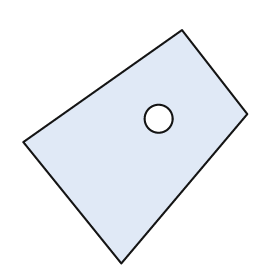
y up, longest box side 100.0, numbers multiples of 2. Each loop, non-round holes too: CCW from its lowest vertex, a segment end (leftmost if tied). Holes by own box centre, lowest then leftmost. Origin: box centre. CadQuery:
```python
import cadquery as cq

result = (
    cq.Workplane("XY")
    .moveTo(-6.0, -50.0)
    .lineTo(48.0, 14.0)
    .lineTo(20.0, 50.0)
    .lineTo(-48.0, 2.0)
    .close()
    .moveTo(10.0, 12.0)
    .circle(6.0)
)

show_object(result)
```